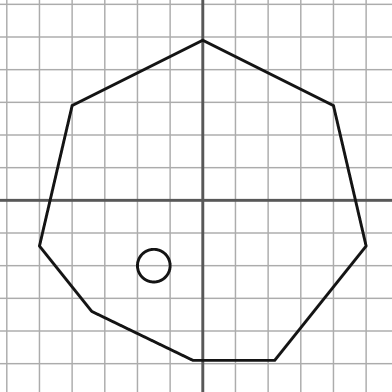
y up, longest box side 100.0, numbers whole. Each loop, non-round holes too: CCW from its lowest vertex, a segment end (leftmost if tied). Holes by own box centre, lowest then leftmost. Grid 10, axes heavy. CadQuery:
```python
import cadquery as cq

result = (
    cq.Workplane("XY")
    .moveTo(-3.0, -49.0)
    .lineTo(22.0, -49.0)
    .lineTo(50.0, -14.0)
    .lineTo(40.0, 29.0)
    .lineTo(0.0, 49.0)
    .lineTo(-40.0, 29.0)
    .lineTo(-50.0, -14.0)
    .lineTo(-34.0, -34.0)
    .close()
    .moveTo(-15.0, -20.0)
    .circle(5.0)
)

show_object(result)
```